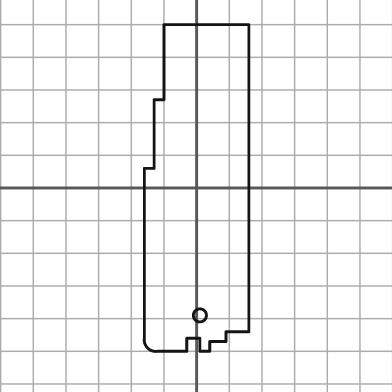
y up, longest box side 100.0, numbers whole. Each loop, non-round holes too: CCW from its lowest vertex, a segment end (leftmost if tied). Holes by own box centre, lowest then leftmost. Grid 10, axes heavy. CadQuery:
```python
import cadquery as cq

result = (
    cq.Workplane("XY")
    .moveTo(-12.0, -50.0)
    .lineTo(-3.0, -50.0)
    .lineTo(-3.0, -46.0)
    .lineTo(1.0, -46.0)
    .lineTo(1.0, -50.0)
    .lineTo(4.0, -50.0)
    .lineTo(4.0, -47.0)
    .lineTo(9.0, -47.0)
    .lineTo(9.0, -44.0)
    .lineTo(16.0, -44.0)
    .lineTo(16.0, 50.0)
    .lineTo(-10.0, 50.0)
    .lineTo(-10.0, 27.0)
    .lineTo(-13.0, 27.0)
    .lineTo(-13.0, 6.0)
    .lineTo(-16.0, 6.0)
    .lineTo(-16.0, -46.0)
    .threePointArc((-15.0, -49.0), (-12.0, -50.0))
    .close()
    .moveTo(1.0, -39.0)
    .circle(2.0)
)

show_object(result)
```